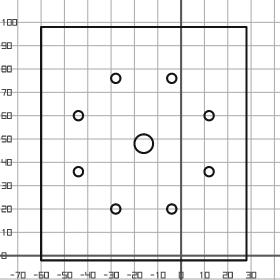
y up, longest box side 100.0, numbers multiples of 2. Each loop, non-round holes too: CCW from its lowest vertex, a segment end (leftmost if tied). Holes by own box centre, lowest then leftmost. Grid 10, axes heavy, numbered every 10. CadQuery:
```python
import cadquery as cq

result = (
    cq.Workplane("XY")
    .moveTo(-60.0, -2.0)
    .lineTo(28.0, -2.0)
    .lineTo(28.0, 98.0)
    .lineTo(-60.0, 98.0)
    .close()
    .moveTo(-28.0, 20.0)
    .circle(2.0)
    .moveTo(-4.0, 20.0)
    .circle(2.0)
    .moveTo(-44.0, 36.0)
    .circle(2.0)
    .moveTo(12.0, 36.0)
    .circle(2.0)
    .moveTo(-16.0, 48.0)
    .circle(4.0)
    .moveTo(-44.0, 60.0)
    .circle(2.0)
    .moveTo(12.0, 60.0)
    .circle(2.0)
    .moveTo(-28.0, 76.0)
    .circle(2.0)
    .moveTo(-4.0, 76.0)
    .circle(2.0)
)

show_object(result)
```